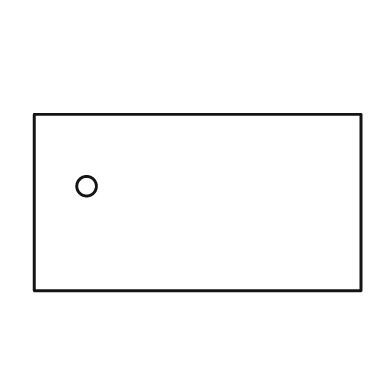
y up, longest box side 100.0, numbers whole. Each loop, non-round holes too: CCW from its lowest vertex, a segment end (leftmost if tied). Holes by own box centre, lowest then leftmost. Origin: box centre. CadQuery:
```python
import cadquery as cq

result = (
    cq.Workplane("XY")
    .moveTo(-50.0, -27.0)
    .lineTo(50.0, -27.0)
    .lineTo(50.0, 27.0)
    .lineTo(-50.0, 27.0)
    .close()
    .moveTo(-34.0, 5.0)
    .circle(3.0)
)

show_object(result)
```